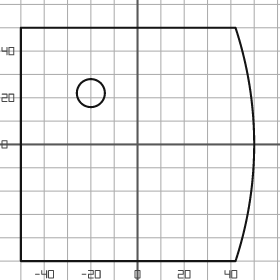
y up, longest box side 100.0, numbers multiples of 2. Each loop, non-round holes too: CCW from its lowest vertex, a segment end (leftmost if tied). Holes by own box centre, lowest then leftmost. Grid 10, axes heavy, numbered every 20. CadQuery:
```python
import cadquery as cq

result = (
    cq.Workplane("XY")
    .moveTo(-50.0, -50.0)
    .lineTo(42.0, -50.0)
    .threePointArc((50.0, 0.0), (42.0, 50.0))
    .lineTo(-50.0, 50.0)
    .close()
    .moveTo(-20.0, 22.0)
    .circle(6.0)
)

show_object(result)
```